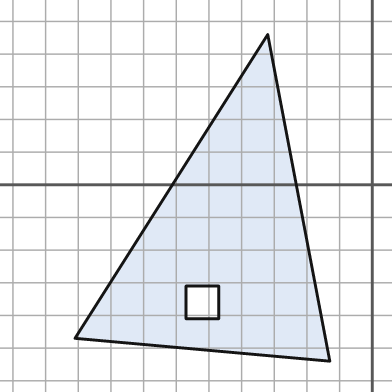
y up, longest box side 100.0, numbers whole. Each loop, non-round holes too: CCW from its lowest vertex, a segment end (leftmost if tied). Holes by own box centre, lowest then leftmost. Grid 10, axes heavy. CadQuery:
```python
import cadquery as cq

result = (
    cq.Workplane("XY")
    .moveTo(-13.0, -54.0)
    .lineTo(-32.0, 46.0)
    .lineTo(-91.0, -47.0)
    .close()
    .moveTo(-57.0, -41.0)
    .lineTo(-47.0, -41.0)
    .lineTo(-47.0, -31.0)
    .lineTo(-57.0, -31.0)
    .close()
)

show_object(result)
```